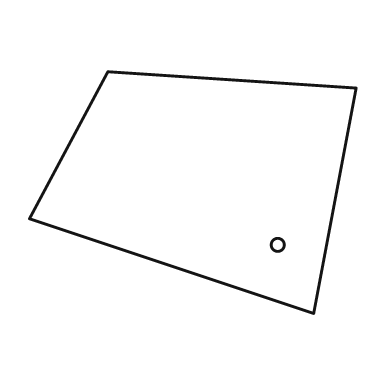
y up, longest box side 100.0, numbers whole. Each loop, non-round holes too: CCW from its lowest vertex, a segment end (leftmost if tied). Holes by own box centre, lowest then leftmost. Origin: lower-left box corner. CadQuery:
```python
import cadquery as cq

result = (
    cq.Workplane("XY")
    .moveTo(87.0, 0.0)
    .lineTo(100.0, 69.0)
    .lineTo(24.0, 74.0)
    .lineTo(0.0, 29.0)
    .close()
    .moveTo(76.0, 21.0)
    .circle(2.0)
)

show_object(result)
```